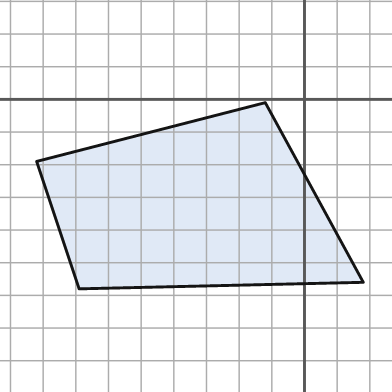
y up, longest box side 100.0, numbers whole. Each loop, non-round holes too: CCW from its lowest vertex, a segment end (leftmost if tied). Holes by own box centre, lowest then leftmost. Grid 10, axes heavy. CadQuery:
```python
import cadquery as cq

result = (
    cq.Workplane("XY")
    .moveTo(-69.0, -58.0)
    .lineTo(18.0, -56.0)
    .lineTo(-12.0, -1.0)
    .lineTo(-82.0, -19.0)
    .close()
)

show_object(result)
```